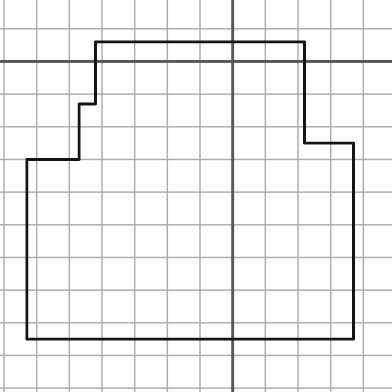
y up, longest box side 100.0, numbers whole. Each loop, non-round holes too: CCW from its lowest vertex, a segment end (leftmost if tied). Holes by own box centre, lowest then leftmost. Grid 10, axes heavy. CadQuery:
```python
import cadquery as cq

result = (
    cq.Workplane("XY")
    .moveTo(-63.0, -85.0)
    .lineTo(37.0, -85.0)
    .lineTo(37.0, -25.0)
    .lineTo(22.0, -25.0)
    .lineTo(22.0, 6.0)
    .lineTo(-42.0, 6.0)
    .lineTo(-42.0, -13.0)
    .lineTo(-47.0, -13.0)
    .lineTo(-47.0, -30.0)
    .lineTo(-63.0, -30.0)
    .close()
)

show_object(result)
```